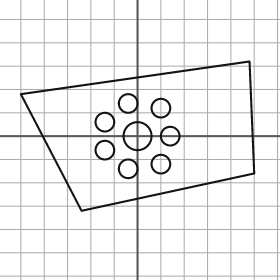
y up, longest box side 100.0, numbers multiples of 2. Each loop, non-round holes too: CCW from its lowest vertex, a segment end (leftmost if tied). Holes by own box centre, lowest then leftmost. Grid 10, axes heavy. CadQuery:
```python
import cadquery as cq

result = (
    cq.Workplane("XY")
    .moveTo(-24.0, -32.0)
    .lineTo(50.0, -16.0)
    .lineTo(48.0, 32.0)
    .lineTo(-50.0, 18.0)
    .close()
    .moveTo(-4.0, -14.0)
    .circle(4.0)
    .moveTo(10.0, -12.0)
    .circle(4.0)
    .moveTo(-14.0, -6.0)
    .circle(4.0)
    .moveTo(0.0, 0.0)
    .circle(6.0)
    .moveTo(14.0, 0.0)
    .circle(4.0)
    .moveTo(-14.0, 6.0)
    .circle(4.0)
    .moveTo(10.0, 12.0)
    .circle(4.0)
    .moveTo(-4.0, 14.0)
    .circle(4.0)
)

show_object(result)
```